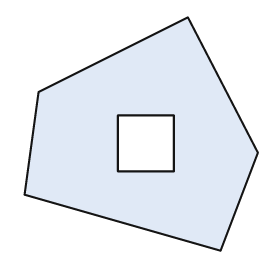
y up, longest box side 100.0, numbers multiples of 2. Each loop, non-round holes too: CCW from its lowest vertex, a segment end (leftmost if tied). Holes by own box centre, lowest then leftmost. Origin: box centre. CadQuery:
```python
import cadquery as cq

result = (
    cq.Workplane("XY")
    .moveTo(34.0, -50.0)
    .lineTo(50.0, -8.0)
    .lineTo(20.0, 50.0)
    .lineTo(-44.0, 18.0)
    .lineTo(-50.0, -26.0)
    .close()
    .moveTo(-10.0, -16.0)
    .lineTo(14.0, -16.0)
    .lineTo(14.0, 8.0)
    .lineTo(-10.0, 8.0)
    .close()
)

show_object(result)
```